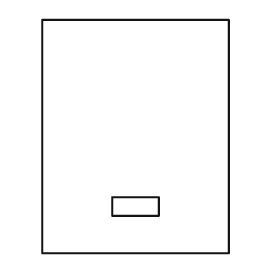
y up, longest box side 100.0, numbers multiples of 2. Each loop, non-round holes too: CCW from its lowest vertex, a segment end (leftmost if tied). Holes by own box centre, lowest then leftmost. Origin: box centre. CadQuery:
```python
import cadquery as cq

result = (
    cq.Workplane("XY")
    .moveTo(-40.0, -50.0)
    .lineTo(40.0, -50.0)
    .lineTo(40.0, 50.0)
    .lineTo(-40.0, 50.0)
    .close()
    .moveTo(-10.0, -34.0)
    .lineTo(10.0, -34.0)
    .lineTo(10.0, -26.0)
    .lineTo(-10.0, -26.0)
    .close()
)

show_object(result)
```